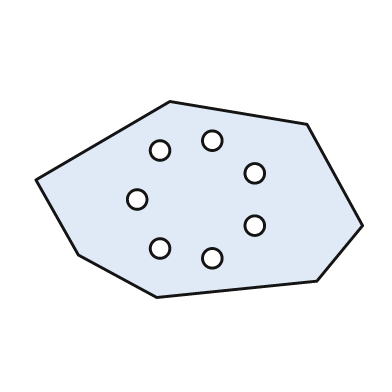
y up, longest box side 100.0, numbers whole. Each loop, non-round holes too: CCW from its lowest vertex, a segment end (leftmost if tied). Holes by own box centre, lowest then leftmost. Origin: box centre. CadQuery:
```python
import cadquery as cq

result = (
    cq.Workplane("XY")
    .moveTo(-13.0, -30.0)
    .lineTo(36.0, -25.0)
    .lineTo(50.0, -8.0)
    .lineTo(33.0, 23.0)
    .lineTo(-9.0, 30.0)
    .lineTo(-50.0, 6.0)
    .lineTo(-37.0, -17.0)
    .close()
    .moveTo(4.0, -18.0)
    .circle(3.0)
    .moveTo(-12.0, -15.0)
    .circle(3.0)
    .moveTo(17.0, -8.0)
    .circle(3.0)
    .moveTo(-19.0, 0.0)
    .circle(3.0)
    .moveTo(17.0, 8.0)
    .circle(3.0)
    .moveTo(-12.0, 15.0)
    .circle(3.0)
    .moveTo(4.0, 18.0)
    .circle(3.0)
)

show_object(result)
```